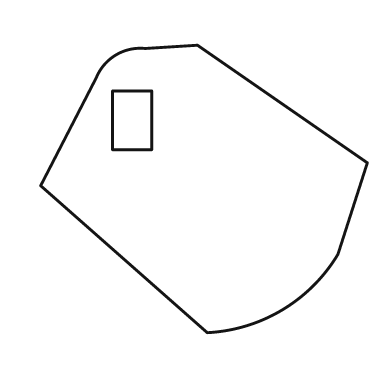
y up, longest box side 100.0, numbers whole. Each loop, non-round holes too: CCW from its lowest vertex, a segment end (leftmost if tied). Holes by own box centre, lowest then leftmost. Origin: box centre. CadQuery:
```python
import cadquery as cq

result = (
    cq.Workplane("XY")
    .moveTo(1.0, -44.0)
    .threePointArc((24.0, -37.0), (41.0, -20.0))
    .lineTo(50.0, 8.0)
    .lineTo(-2.0, 44.0)
    .lineTo(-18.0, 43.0)
    .threePointArc((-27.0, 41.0), (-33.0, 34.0))
    .lineTo(-50.0, 1.0)
    .close()
    .moveTo(-28.0, 12.0)
    .lineTo(-16.0, 12.0)
    .lineTo(-16.0, 30.0)
    .lineTo(-28.0, 30.0)
    .close()
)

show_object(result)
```